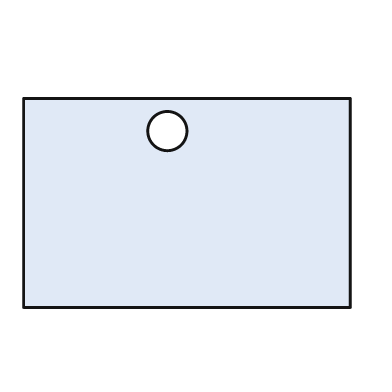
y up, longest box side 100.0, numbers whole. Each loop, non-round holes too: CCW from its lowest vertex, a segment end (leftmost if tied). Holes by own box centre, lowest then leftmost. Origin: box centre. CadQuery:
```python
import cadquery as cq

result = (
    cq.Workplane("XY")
    .moveTo(-50.0, -32.0)
    .lineTo(50.0, -32.0)
    .lineTo(50.0, 32.0)
    .lineTo(-50.0, 32.0)
    .close()
    .moveTo(-6.0, 22.0)
    .circle(6.0)
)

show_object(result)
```